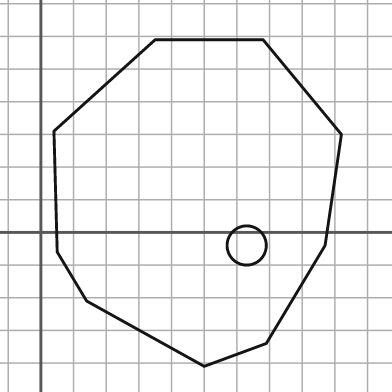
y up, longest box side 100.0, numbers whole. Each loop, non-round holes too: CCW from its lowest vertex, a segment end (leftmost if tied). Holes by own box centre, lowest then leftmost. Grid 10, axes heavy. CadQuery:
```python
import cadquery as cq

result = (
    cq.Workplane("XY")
    .moveTo(50.0, -41.0)
    .lineTo(69.0, -34.0)
    .lineTo(87.0, -4.0)
    .lineTo(92.0, 30.0)
    .lineTo(68.0, 59.0)
    .lineTo(35.0, 59.0)
    .lineTo(4.0, 31.0)
    .lineTo(5.0, -6.0)
    .lineTo(14.0, -21.0)
    .close()
    .moveTo(63.0, -4.0)
    .circle(6.0)
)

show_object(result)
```